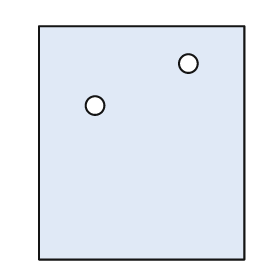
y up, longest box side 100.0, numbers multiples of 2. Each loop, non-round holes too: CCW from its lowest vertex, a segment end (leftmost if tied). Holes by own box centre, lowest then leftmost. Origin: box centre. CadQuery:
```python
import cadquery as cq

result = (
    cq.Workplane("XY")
    .moveTo(-44.0, -50.0)
    .lineTo(44.0, -50.0)
    .lineTo(44.0, 50.0)
    .lineTo(-44.0, 50.0)
    .close()
    .moveTo(-20.0, 16.0)
    .circle(4.0)
    .moveTo(20.0, 34.0)
    .circle(4.0)
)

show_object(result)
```